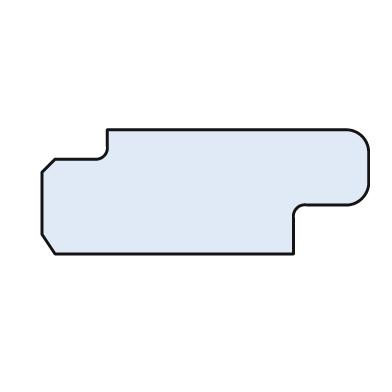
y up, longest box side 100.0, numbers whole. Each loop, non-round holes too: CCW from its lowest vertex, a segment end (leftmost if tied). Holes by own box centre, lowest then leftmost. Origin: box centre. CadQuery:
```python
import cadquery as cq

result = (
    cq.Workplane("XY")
    .moveTo(-46.0, -19.0)
    .lineTo(27.0, -19.0)
    .lineTo(27.0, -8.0)
    .threePointArc((28.0, -5.0), (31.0, -4.0))
    .lineTo(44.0, -4.0)
    .threePointArc((48.0, -2.0), (50.0, 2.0))
    .lineTo(50.0, 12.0)
    .threePointArc((48.0, 17.0), (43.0, 19.0))
    .lineTo(-30.0, 19.0)
    .lineTo(-30.0, 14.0)
    .threePointArc((-31.0, 11.0), (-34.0, 10.0))
    .lineTo(-46.0, 10.0)
    .lineTo(-50.0, 6.0)
    .lineTo(-50.0, -13.0)
    .close()
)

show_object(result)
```